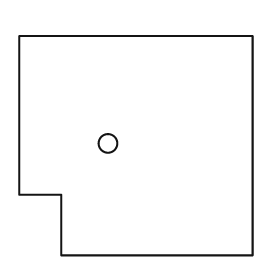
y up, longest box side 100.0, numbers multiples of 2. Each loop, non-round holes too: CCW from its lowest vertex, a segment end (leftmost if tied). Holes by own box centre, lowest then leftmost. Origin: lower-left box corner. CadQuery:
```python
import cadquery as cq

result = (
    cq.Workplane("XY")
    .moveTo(18.0, 0.0)
    .lineTo(100.0, 0.0)
    .lineTo(100.0, 94.0)
    .lineTo(0.0, 94.0)
    .lineTo(0.0, 26.0)
    .lineTo(18.0, 26.0)
    .close()
    .moveTo(38.0, 48.0)
    .circle(4.0)
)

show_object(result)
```